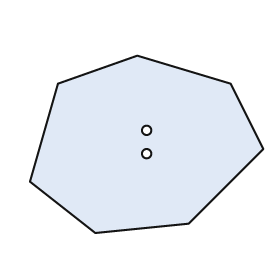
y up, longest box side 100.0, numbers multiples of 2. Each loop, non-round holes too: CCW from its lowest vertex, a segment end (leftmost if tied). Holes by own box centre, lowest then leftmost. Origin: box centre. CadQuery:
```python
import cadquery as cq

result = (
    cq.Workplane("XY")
    .moveTo(-22.0, -38.0)
    .lineTo(18.0, -34.0)
    .lineTo(50.0, -2.0)
    .lineTo(36.0, 26.0)
    .lineTo(-4.0, 38.0)
    .lineTo(-38.0, 26.0)
    .lineTo(-50.0, -16.0)
    .close()
    .moveTo(0.0, -4.0)
    .circle(2.0)
    .moveTo(0.0, 6.0)
    .circle(2.0)
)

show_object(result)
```